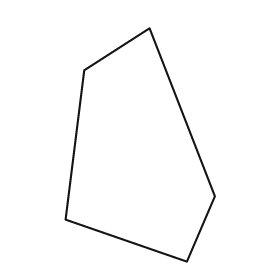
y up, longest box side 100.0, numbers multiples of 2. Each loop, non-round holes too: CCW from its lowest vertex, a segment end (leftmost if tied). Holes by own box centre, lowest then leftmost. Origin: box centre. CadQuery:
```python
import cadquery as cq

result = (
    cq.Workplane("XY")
    .moveTo(20.0, -50.0)
    .lineTo(32.0, -22.0)
    .lineTo(4.0, 50.0)
    .lineTo(-24.0, 32.0)
    .lineTo(-32.0, -32.0)
    .close()
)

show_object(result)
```